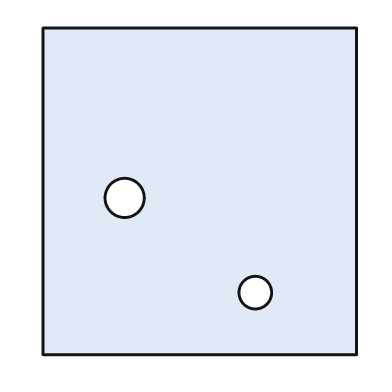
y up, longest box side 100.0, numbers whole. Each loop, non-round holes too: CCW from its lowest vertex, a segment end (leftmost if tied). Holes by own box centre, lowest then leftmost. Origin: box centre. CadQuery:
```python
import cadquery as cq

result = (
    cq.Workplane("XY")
    .moveTo(-48.0, -50.0)
    .lineTo(48.0, -50.0)
    .lineTo(48.0, 50.0)
    .lineTo(-48.0, 50.0)
    .close()
    .moveTo(17.0, -31.0)
    .circle(5.0)
    .moveTo(-23.0, -2.0)
    .circle(6.0)
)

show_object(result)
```